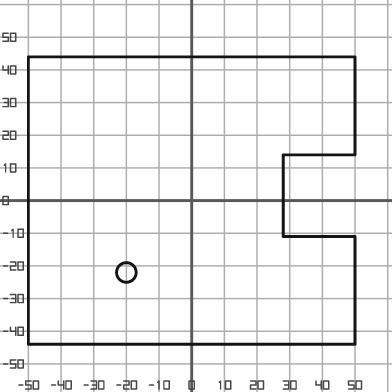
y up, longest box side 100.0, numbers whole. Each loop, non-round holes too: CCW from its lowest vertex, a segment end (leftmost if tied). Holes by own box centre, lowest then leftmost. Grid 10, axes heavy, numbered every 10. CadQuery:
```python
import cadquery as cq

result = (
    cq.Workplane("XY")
    .moveTo(-50.0, -44.0)
    .lineTo(50.0, -44.0)
    .lineTo(50.0, -11.0)
    .lineTo(28.0, -11.0)
    .lineTo(28.0, 14.0)
    .lineTo(50.0, 14.0)
    .lineTo(50.0, 44.0)
    .lineTo(-50.0, 44.0)
    .close()
    .moveTo(-20.0, -22.0)
    .circle(3.0)
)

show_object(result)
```